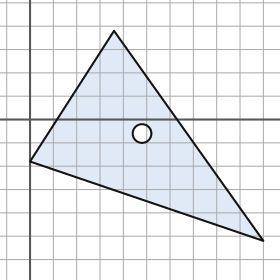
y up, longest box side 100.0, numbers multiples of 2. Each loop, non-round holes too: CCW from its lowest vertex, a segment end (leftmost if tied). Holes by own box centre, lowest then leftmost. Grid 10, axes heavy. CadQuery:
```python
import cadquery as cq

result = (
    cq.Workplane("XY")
    .moveTo(100.0, -52.0)
    .lineTo(36.0, 38.0)
    .lineTo(0.0, -18.0)
    .close()
    .moveTo(48.0, -6.0)
    .circle(4.0)
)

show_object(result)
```